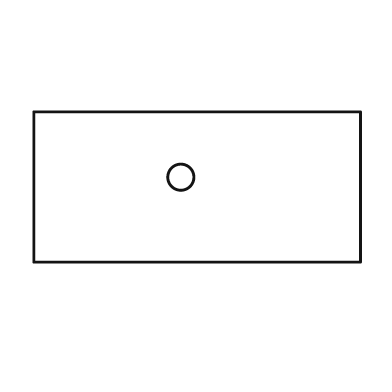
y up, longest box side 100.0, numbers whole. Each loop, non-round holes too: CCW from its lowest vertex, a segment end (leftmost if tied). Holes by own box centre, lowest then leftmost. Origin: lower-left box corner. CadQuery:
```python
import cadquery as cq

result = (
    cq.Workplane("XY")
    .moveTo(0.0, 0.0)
    .lineTo(100.0, 0.0)
    .lineTo(100.0, 46.0)
    .lineTo(0.0, 46.0)
    .close()
    .moveTo(45.0, 26.0)
    .circle(4.0)
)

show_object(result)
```